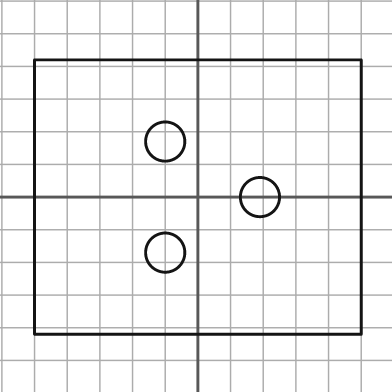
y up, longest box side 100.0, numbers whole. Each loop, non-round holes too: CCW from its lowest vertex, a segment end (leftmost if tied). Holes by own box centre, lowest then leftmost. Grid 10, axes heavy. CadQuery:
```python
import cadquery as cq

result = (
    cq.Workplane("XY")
    .moveTo(-50.0, -42.0)
    .lineTo(50.0, -42.0)
    .lineTo(50.0, 42.0)
    .lineTo(-50.0, 42.0)
    .close()
    .moveTo(-10.0, -17.0)
    .circle(6.0)
    .moveTo(19.0, 0.0)
    .circle(6.0)
    .moveTo(-10.0, 17.0)
    .circle(6.0)
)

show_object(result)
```